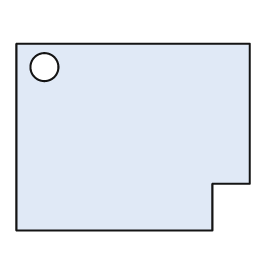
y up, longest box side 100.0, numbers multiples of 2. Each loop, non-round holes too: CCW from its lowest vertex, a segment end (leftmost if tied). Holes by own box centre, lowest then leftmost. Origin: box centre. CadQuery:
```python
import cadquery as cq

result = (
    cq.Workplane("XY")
    .moveTo(-50.0, -40.0)
    .lineTo(34.0, -40.0)
    .lineTo(34.0, -20.0)
    .lineTo(50.0, -20.0)
    .lineTo(50.0, 40.0)
    .lineTo(-50.0, 40.0)
    .close()
    .moveTo(-38.0, 30.0)
    .circle(6.0)
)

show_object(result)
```